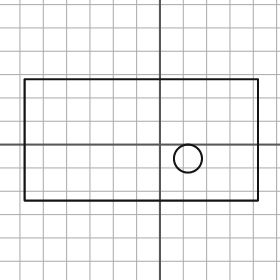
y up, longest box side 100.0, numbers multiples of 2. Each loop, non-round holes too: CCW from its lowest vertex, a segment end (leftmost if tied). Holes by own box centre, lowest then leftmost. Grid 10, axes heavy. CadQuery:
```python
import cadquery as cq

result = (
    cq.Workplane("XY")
    .moveTo(-58.0, -24.0)
    .lineTo(42.0, -24.0)
    .lineTo(42.0, 28.0)
    .lineTo(-58.0, 28.0)
    .close()
    .moveTo(12.0, -6.0)
    .circle(6.0)
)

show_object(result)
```